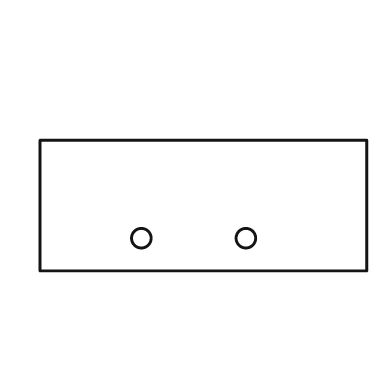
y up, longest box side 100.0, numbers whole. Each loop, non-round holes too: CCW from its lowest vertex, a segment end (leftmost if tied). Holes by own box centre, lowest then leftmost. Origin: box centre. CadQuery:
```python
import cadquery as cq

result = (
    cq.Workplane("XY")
    .moveTo(-50.0, -20.0)
    .lineTo(50.0, -20.0)
    .lineTo(50.0, 20.0)
    .lineTo(-50.0, 20.0)
    .close()
    .moveTo(-19.0, -10.0)
    .circle(3.0)
    .moveTo(13.0, -10.0)
    .circle(3.0)
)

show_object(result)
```